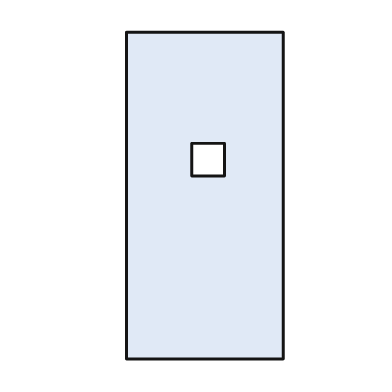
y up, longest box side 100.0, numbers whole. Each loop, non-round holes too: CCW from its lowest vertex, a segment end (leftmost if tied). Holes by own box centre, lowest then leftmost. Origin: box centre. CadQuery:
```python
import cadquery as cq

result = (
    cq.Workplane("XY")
    .moveTo(-24.0, -50.0)
    .lineTo(24.0, -50.0)
    .lineTo(24.0, 50.0)
    .lineTo(-24.0, 50.0)
    .close()
    .moveTo(-4.0, 6.0)
    .lineTo(6.0, 6.0)
    .lineTo(6.0, 16.0)
    .lineTo(-4.0, 16.0)
    .close()
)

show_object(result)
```